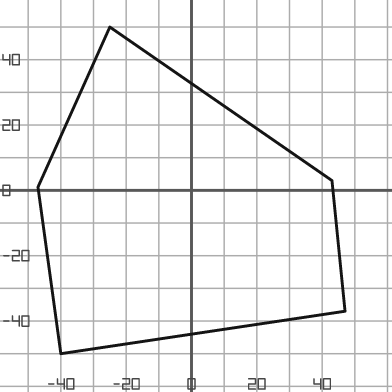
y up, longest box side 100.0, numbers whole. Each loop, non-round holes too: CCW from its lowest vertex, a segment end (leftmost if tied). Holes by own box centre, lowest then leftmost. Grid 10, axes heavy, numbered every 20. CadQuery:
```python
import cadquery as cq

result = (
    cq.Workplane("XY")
    .moveTo(-40.0, -50.0)
    .lineTo(47.0, -37.0)
    .lineTo(43.0, 3.0)
    .lineTo(-25.0, 50.0)
    .lineTo(-47.0, 1.0)
    .close()
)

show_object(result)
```